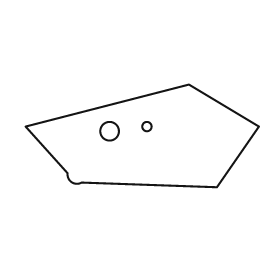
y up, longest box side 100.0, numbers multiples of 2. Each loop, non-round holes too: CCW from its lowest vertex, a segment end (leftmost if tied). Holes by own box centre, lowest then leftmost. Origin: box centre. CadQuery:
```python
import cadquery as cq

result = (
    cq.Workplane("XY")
    .moveTo(32.0, -22.0)
    .lineTo(50.0, 4.0)
    .lineTo(20.0, 22.0)
    .lineTo(-50.0, 4.0)
    .lineTo(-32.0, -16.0)
    .threePointArc((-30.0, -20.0), (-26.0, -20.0))
    .close()
    .moveTo(-14.0, 2.0)
    .circle(4.0)
    .moveTo(2.0, 4.0)
    .circle(2.0)
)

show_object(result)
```